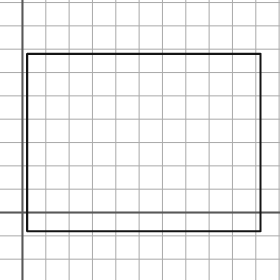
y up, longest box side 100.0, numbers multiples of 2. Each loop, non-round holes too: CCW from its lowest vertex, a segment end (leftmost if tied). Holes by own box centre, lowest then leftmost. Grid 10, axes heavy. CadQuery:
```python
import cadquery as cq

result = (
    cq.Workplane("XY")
    .moveTo(2.0, -8.0)
    .lineTo(102.0, -8.0)
    .lineTo(102.0, 68.0)
    .lineTo(2.0, 68.0)
    .close()
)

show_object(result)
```